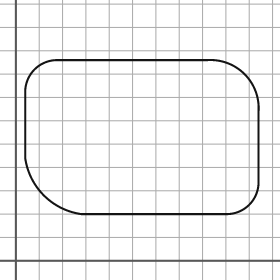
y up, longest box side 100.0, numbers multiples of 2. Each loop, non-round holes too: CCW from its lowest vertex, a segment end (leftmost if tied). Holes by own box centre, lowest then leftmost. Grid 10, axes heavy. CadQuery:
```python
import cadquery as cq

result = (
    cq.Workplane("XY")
    .moveTo(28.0, 20.0)
    .lineTo(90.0, 20.0)
    .threePointArc((100.0, 24.0), (104.0, 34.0))
    .lineTo(104.0, 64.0)
    .threePointArc((98.0, 80.0), (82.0, 86.0))
    .lineTo(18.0, 86.0)
    .threePointArc((8.0, 82.0), (4.0, 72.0))
    .lineTo(4.0, 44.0)
    .threePointArc((12.0, 28.0), (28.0, 20.0))
    .close()
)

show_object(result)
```